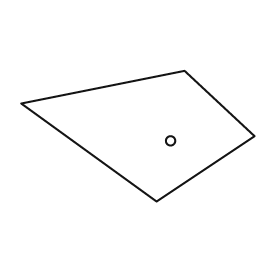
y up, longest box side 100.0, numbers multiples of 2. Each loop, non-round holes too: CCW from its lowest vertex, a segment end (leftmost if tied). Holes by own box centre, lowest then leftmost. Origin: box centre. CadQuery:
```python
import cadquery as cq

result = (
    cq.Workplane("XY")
    .moveTo(8.0, -28.0)
    .lineTo(50.0, 0.0)
    .lineTo(20.0, 28.0)
    .lineTo(-50.0, 14.0)
    .close()
    .moveTo(14.0, -2.0)
    .circle(2.0)
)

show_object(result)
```